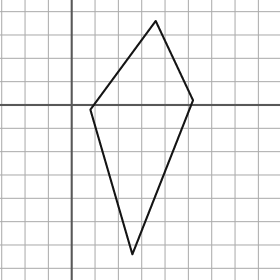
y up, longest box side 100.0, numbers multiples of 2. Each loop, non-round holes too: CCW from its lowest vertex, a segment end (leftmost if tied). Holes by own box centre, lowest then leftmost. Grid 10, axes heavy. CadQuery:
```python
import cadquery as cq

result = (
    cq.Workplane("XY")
    .moveTo(26.0, -64.0)
    .lineTo(52.0, 2.0)
    .lineTo(36.0, 36.0)
    .lineTo(8.0, -2.0)
    .close()
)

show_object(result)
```